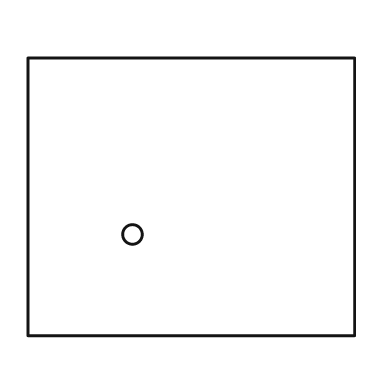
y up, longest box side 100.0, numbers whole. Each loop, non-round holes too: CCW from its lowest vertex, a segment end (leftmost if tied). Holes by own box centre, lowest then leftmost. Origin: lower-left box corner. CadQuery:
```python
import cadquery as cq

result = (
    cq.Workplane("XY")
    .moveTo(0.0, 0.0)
    .lineTo(100.0, 0.0)
    .lineTo(100.0, 85.0)
    .lineTo(0.0, 85.0)
    .close()
    .moveTo(32.0, 31.0)
    .circle(3.0)
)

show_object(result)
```